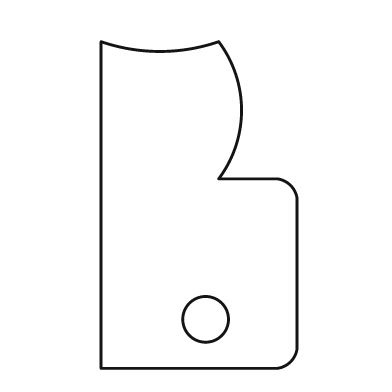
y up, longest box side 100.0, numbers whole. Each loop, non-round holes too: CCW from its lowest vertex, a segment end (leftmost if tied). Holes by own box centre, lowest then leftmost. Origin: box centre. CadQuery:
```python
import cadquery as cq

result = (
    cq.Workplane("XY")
    .moveTo(-30.0, -50.0)
    .lineTo(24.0, -50.0)
    .threePointArc((28.0, -48.0), (30.0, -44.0))
    .lineTo(30.0, 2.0)
    .threePointArc((28.0, 6.0), (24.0, 8.0))
    .lineTo(6.0, 8.0)
    .threePointArc((13.0, 29.0), (6.0, 50.0))
    .threePointArc((-12.0, 47.0), (-30.0, 50.0))
    .close()
    .moveTo(2.0, -35.0)
    .circle(7.0)
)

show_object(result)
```